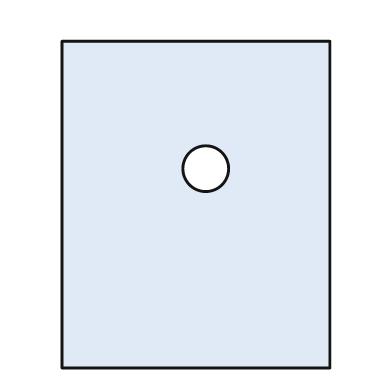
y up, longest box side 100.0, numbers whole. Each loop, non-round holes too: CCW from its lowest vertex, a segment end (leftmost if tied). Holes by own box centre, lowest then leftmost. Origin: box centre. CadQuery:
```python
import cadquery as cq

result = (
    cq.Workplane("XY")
    .moveTo(-41.0, -50.0)
    .lineTo(41.0, -50.0)
    .lineTo(41.0, 50.0)
    .lineTo(-41.0, 50.0)
    .close()
    .moveTo(3.0, 11.0)
    .circle(7.0)
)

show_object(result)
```